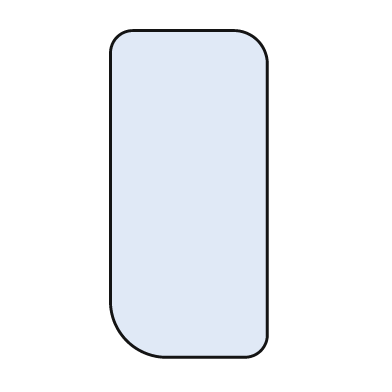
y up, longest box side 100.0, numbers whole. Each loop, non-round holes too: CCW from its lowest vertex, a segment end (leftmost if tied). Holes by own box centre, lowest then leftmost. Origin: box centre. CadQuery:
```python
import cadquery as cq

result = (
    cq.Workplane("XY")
    .moveTo(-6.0, -50.0)
    .lineTo(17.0, -50.0)
    .threePointArc((22.0, -48.0), (24.0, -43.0))
    .lineTo(24.0, 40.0)
    .threePointArc((21.0, 47.0), (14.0, 50.0))
    .lineTo(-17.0, 50.0)
    .threePointArc((-22.0, 48.0), (-24.0, 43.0))
    .lineTo(-24.0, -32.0)
    .threePointArc((-19.0, -45.0), (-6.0, -50.0))
    .close()
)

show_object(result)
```